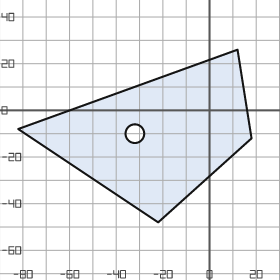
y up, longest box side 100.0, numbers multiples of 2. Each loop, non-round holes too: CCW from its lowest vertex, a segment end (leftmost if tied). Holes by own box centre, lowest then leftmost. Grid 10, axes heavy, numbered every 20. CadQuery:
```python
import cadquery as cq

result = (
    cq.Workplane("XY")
    .moveTo(-22.0, -48.0)
    .lineTo(18.0, -12.0)
    .lineTo(12.0, 26.0)
    .lineTo(-82.0, -8.0)
    .close()
    .moveTo(-32.0, -10.0)
    .circle(4.0)
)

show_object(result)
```